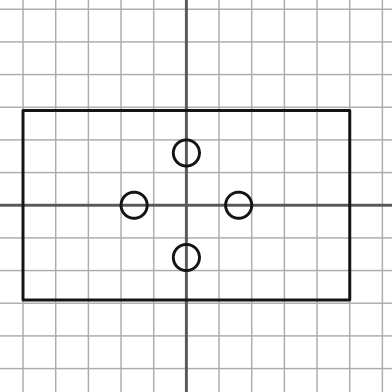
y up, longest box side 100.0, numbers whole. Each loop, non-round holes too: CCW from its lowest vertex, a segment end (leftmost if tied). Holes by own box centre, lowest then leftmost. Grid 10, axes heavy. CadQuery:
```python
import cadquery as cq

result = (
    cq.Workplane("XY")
    .moveTo(-50.0, -29.0)
    .lineTo(50.0, -29.0)
    .lineTo(50.0, 29.0)
    .lineTo(-50.0, 29.0)
    .close()
    .moveTo(0.0, -16.0)
    .circle(4.0)
    .moveTo(-16.0, 0.0)
    .circle(4.0)
    .moveTo(16.0, 0.0)
    .circle(4.0)
    .moveTo(0.0, 16.0)
    .circle(4.0)
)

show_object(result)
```